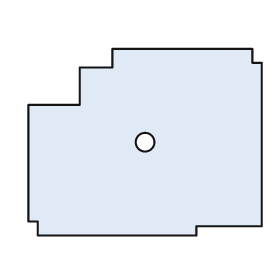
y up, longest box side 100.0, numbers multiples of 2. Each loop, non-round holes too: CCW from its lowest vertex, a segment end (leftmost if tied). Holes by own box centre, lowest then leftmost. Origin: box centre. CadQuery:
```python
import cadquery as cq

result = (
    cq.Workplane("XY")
    .moveTo(-46.0, -40.0)
    .lineTo(22.0, -40.0)
    .lineTo(22.0, -36.0)
    .lineTo(50.0, -36.0)
    .lineTo(50.0, 34.0)
    .lineTo(46.0, 34.0)
    .lineTo(46.0, 40.0)
    .lineTo(-14.0, 40.0)
    .lineTo(-14.0, 32.0)
    .lineTo(-28.0, 32.0)
    .lineTo(-28.0, 16.0)
    .lineTo(-50.0, 16.0)
    .lineTo(-50.0, -34.0)
    .lineTo(-46.0, -34.0)
    .close()
    .moveTo(0.0, 0.0)
    .circle(4.0)
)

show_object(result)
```